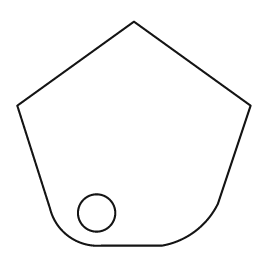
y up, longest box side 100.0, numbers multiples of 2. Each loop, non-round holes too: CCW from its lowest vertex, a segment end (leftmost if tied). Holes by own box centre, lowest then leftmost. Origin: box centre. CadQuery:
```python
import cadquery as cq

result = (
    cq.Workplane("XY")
    .moveTo(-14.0, -48.0)
    .lineTo(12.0, -48.0)
    .threePointArc((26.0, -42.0), (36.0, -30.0))
    .lineTo(50.0, 12.0)
    .lineTo(0.0, 48.0)
    .lineTo(-50.0, 12.0)
    .lineTo(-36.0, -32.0)
    .threePointArc((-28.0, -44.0), (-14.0, -48.0))
    .close()
    .moveTo(-16.0, -34.0)
    .circle(8.0)
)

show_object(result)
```